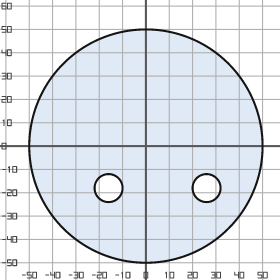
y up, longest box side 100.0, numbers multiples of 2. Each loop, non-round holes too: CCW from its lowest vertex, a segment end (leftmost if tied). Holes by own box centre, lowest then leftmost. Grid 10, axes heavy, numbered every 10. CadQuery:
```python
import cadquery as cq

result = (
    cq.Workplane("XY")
    .moveTo(0.0, 0.0)
    .circle(50.0)
    .moveTo(-16.0, -18.0)
    .circle(6.0)
    .moveTo(26.0, -18.0)
    .circle(6.0)
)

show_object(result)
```